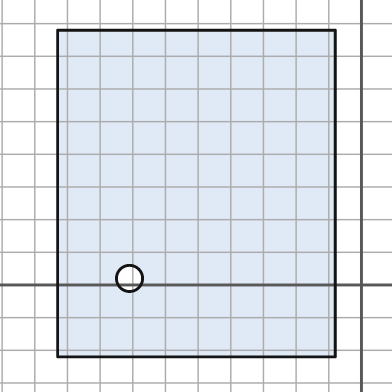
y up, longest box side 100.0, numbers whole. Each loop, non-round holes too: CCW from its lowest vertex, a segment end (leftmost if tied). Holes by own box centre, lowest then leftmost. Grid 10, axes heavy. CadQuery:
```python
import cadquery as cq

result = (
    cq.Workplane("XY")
    .moveTo(-93.0, -22.0)
    .lineTo(-8.0, -22.0)
    .lineTo(-8.0, 78.0)
    .lineTo(-93.0, 78.0)
    .close()
    .moveTo(-71.0, 2.0)
    .circle(4.0)
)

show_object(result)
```